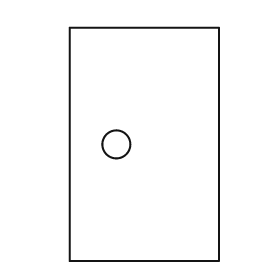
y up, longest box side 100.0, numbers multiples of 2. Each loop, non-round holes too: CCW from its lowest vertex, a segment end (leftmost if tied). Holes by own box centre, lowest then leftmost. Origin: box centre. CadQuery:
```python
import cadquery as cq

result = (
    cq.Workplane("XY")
    .moveTo(-32.0, -50.0)
    .lineTo(32.0, -50.0)
    .lineTo(32.0, 50.0)
    .lineTo(-32.0, 50.0)
    .close()
    .moveTo(-12.0, 0.0)
    .circle(6.0)
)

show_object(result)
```